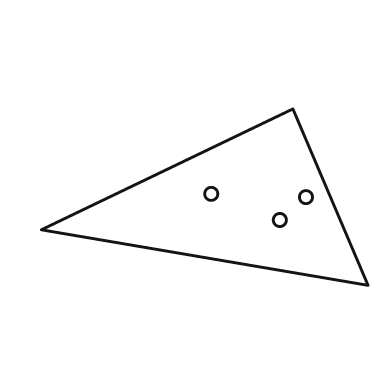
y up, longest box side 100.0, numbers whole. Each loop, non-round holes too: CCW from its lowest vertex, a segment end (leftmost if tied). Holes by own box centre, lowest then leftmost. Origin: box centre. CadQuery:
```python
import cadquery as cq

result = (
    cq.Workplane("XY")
    .moveTo(50.0, -27.0)
    .lineTo(27.0, 27.0)
    .lineTo(-50.0, -10.0)
    .close()
    .moveTo(23.0, -7.0)
    .circle(2.0)
    .moveTo(31.0, 0.0)
    .circle(2.0)
    .moveTo(2.0, 1.0)
    .circle(2.0)
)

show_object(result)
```